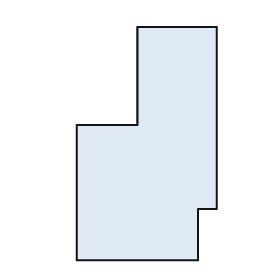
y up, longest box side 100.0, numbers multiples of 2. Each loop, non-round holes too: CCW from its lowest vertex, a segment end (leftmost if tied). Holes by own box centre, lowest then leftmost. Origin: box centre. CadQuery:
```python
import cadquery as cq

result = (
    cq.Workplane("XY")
    .moveTo(-30.0, -50.0)
    .lineTo(22.0, -50.0)
    .lineTo(22.0, -28.0)
    .lineTo(30.0, -28.0)
    .lineTo(30.0, 50.0)
    .lineTo(-4.0, 50.0)
    .lineTo(-4.0, 8.0)
    .lineTo(-30.0, 8.0)
    .close()
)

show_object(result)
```